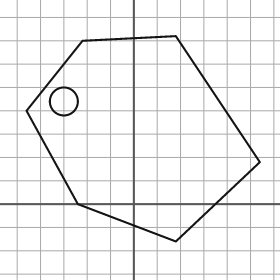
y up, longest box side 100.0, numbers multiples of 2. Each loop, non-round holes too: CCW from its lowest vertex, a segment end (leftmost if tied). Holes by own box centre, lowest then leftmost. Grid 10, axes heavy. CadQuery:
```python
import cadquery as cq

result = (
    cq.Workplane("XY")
    .moveTo(18.0, -16.0)
    .lineTo(54.0, 18.0)
    .lineTo(18.0, 72.0)
    .lineTo(-22.0, 70.0)
    .lineTo(-46.0, 40.0)
    .lineTo(-24.0, 0.0)
    .close()
    .moveTo(-30.0, 44.0)
    .circle(6.0)
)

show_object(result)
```